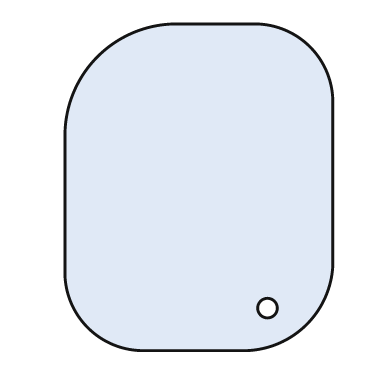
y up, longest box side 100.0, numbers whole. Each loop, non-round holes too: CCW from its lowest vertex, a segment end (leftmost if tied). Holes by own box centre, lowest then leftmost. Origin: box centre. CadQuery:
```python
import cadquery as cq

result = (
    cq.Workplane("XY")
    .moveTo(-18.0, -50.0)
    .lineTo(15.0, -50.0)
    .threePointArc((33.0, -42.0), (41.0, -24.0))
    .lineTo(41.0, 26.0)
    .threePointArc((34.0, 43.0), (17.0, 50.0))
    .lineTo(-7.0, 50.0)
    .threePointArc((-31.0, 40.0), (-41.0, 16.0))
    .lineTo(-41.0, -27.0)
    .threePointArc((-34.0, -43.0), (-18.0, -50.0))
    .close()
    .moveTo(21.0, -37.0)
    .circle(3.0)
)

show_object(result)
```